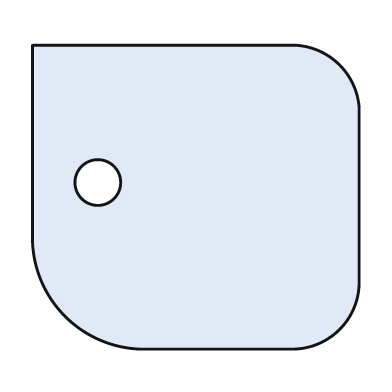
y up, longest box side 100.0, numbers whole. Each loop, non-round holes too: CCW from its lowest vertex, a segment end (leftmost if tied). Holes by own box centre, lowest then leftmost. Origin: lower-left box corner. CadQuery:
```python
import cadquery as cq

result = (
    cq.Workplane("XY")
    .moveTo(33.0, 0.0)
    .lineTo(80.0, 0.0)
    .threePointArc((94.0, 6.0), (100.0, 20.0))
    .lineTo(100.0, 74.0)
    .threePointArc((94.0, 87.0), (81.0, 93.0))
    .lineTo(0.0, 93.0)
    .lineTo(0.0, 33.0)
    .threePointArc((10.0, 10.0), (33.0, 0.0))
    .close()
    .moveTo(20.0, 51.0)
    .circle(7.0)
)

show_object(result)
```